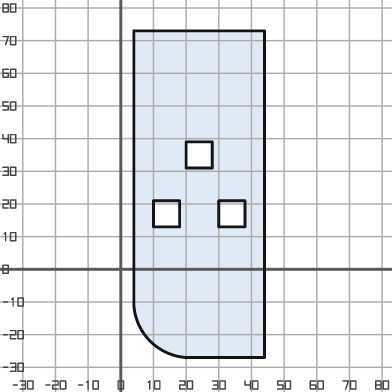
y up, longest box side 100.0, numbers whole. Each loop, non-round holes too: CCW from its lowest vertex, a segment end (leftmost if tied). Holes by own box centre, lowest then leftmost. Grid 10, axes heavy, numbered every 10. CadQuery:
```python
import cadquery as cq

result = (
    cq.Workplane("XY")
    .moveTo(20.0, -27.0)
    .lineTo(44.0, -27.0)
    .lineTo(44.0, 73.0)
    .lineTo(4.0, 73.0)
    .lineTo(4.0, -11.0)
    .threePointArc((9.0, -22.0), (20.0, -27.0))
    .close()
    .moveTo(10.0, 13.0)
    .lineTo(18.0, 13.0)
    .lineTo(18.0, 21.0)
    .lineTo(10.0, 21.0)
    .close()
    .moveTo(30.0, 13.0)
    .lineTo(38.0, 13.0)
    .lineTo(38.0, 21.0)
    .lineTo(30.0, 21.0)
    .close()
    .moveTo(20.0, 31.0)
    .lineTo(28.0, 31.0)
    .lineTo(28.0, 39.0)
    .lineTo(20.0, 39.0)
    .close()
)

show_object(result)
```